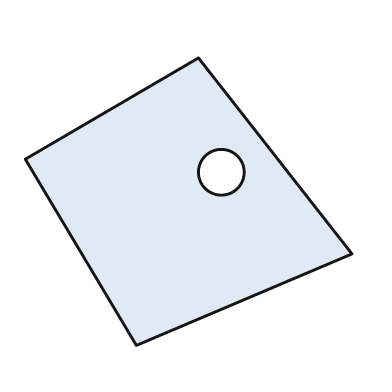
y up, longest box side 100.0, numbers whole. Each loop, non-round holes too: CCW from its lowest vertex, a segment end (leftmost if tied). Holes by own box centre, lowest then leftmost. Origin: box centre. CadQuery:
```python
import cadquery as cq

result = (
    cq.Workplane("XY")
    .moveTo(-16.0, -44.0)
    .lineTo(50.0, -16.0)
    .lineTo(3.0, 44.0)
    .lineTo(-50.0, 13.0)
    .close()
    .moveTo(10.0, 9.0)
    .circle(7.0)
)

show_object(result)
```